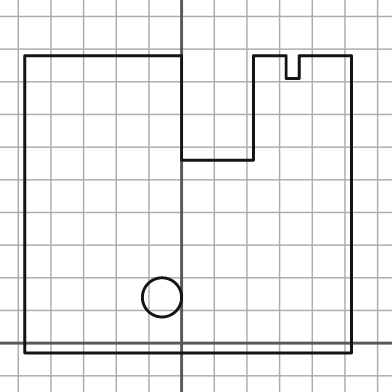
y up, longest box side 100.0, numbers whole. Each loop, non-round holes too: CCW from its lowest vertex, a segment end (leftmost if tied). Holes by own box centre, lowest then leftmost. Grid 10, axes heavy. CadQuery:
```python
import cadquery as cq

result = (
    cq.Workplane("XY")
    .moveTo(-48.0, -3.0)
    .lineTo(52.0, -3.0)
    .lineTo(52.0, 88.0)
    .lineTo(36.0, 88.0)
    .lineTo(36.0, 81.0)
    .lineTo(32.0, 81.0)
    .lineTo(32.0, 88.0)
    .lineTo(22.0, 88.0)
    .lineTo(22.0, 56.0)
    .lineTo(0.0, 56.0)
    .lineTo(0.0, 88.0)
    .lineTo(-48.0, 88.0)
    .close()
    .moveTo(-6.0, 14.0)
    .circle(6.0)
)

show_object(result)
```